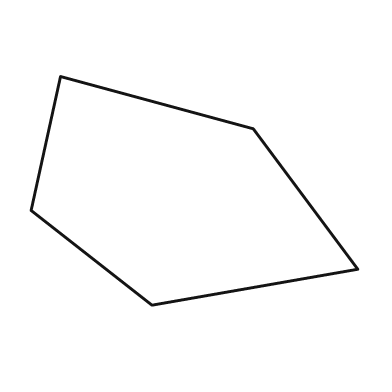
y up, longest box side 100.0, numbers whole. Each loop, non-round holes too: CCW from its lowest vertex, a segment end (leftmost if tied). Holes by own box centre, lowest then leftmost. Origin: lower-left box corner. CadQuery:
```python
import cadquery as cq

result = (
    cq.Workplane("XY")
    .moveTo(37.0, 0.0)
    .lineTo(100.0, 11.0)
    .lineTo(68.0, 54.0)
    .lineTo(9.0, 70.0)
    .lineTo(0.0, 29.0)
    .close()
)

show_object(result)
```